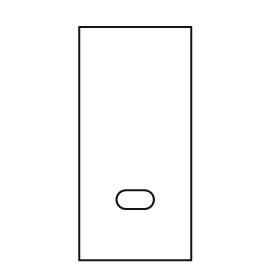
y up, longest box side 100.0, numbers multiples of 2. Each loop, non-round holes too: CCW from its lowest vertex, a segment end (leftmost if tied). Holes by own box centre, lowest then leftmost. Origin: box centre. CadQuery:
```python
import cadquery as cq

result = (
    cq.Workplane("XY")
    .moveTo(-24.0, -50.0)
    .lineTo(24.0, -50.0)
    .lineTo(24.0, 50.0)
    .lineTo(-24.0, 50.0)
    .close()
    .moveTo(-4.0, -28.0)
    .lineTo(4.0, -28.0)
    .threePointArc((8.0, -24.0), (4.0, -20.0))
    .lineTo(-4.0, -20.0)
    .threePointArc((-8.0, -24.0), (-4.0, -28.0))
    .close()
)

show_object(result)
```